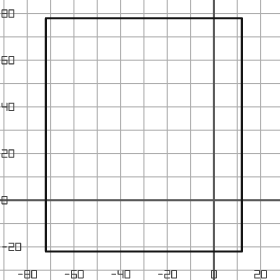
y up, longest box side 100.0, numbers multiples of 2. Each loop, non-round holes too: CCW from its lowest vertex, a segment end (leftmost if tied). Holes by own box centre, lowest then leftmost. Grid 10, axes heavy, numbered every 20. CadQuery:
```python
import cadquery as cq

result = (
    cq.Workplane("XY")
    .moveTo(-72.0, -22.0)
    .lineTo(12.0, -22.0)
    .lineTo(12.0, 78.0)
    .lineTo(-72.0, 78.0)
    .close()
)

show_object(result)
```